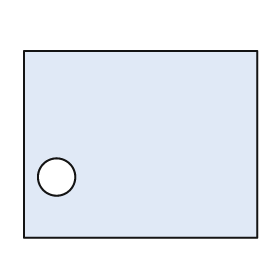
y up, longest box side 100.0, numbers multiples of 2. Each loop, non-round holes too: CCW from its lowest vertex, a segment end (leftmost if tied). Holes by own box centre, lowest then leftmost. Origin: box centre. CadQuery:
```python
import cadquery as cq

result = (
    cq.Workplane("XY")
    .moveTo(-50.0, -40.0)
    .lineTo(50.0, -40.0)
    .lineTo(50.0, 40.0)
    .lineTo(-50.0, 40.0)
    .close()
    .moveTo(-36.0, -14.0)
    .circle(8.0)
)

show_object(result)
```